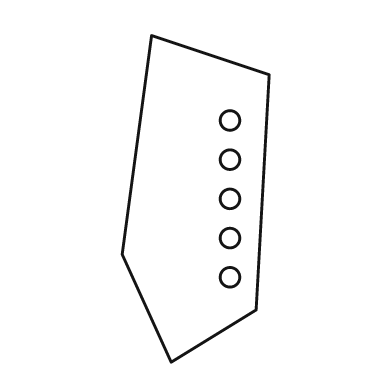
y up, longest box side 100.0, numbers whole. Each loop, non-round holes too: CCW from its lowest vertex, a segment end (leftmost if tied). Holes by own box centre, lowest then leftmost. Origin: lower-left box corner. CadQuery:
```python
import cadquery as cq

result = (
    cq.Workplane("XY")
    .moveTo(15.0, 0.0)
    .lineTo(41.0, 16.0)
    .lineTo(45.0, 88.0)
    .lineTo(9.0, 100.0)
    .lineTo(0.0, 33.0)
    .close()
    .moveTo(33.0, 26.0)
    .circle(3.0)
    .moveTo(33.0, 38.0)
    .circle(3.0)
    .moveTo(33.0, 50.0)
    .circle(3.0)
    .moveTo(33.0, 62.0)
    .circle(3.0)
    .moveTo(33.0, 74.0)
    .circle(3.0)
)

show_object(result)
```